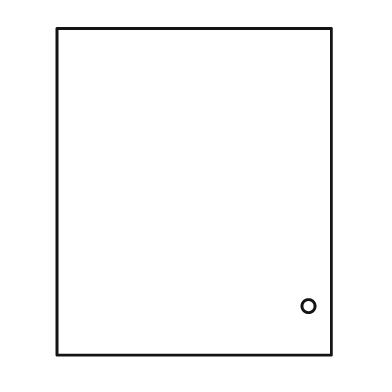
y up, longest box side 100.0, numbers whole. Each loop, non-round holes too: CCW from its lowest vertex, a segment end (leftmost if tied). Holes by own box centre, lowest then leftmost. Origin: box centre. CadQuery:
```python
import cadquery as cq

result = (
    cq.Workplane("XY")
    .moveTo(-42.0, -50.0)
    .lineTo(42.0, -50.0)
    .lineTo(42.0, 50.0)
    .lineTo(-42.0, 50.0)
    .close()
    .moveTo(35.0, -35.0)
    .circle(2.0)
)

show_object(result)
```